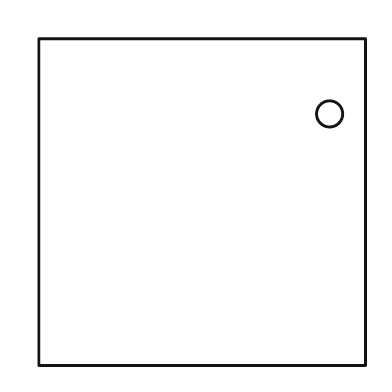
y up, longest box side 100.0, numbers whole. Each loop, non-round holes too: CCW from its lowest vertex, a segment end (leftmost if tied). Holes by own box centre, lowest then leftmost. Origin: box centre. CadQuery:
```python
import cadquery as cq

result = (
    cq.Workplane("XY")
    .moveTo(-50.0, -50.0)
    .lineTo(50.0, -50.0)
    .lineTo(50.0, 50.0)
    .lineTo(-50.0, 50.0)
    .close()
    .moveTo(39.0, 27.0)
    .circle(4.0)
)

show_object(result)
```